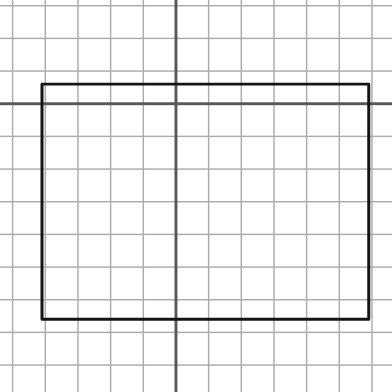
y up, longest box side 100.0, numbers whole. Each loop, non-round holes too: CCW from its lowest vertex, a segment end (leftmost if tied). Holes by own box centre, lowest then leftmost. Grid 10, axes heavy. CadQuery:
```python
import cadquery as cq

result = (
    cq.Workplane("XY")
    .moveTo(-41.0, -66.0)
    .lineTo(59.0, -66.0)
    .lineTo(59.0, 6.0)
    .lineTo(-41.0, 6.0)
    .close()
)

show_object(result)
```